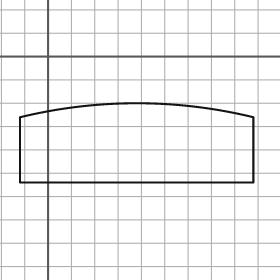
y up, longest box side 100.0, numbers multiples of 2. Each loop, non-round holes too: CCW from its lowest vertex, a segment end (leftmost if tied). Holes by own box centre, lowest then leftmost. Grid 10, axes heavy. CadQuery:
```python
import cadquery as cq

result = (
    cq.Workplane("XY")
    .moveTo(-12.0, -54.0)
    .lineTo(88.0, -54.0)
    .lineTo(88.0, -26.0)
    .threePointArc((38.0, -20.0), (-12.0, -26.0))
    .close()
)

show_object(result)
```